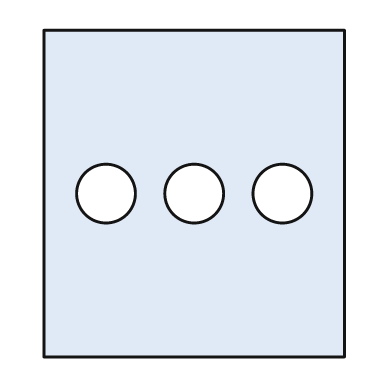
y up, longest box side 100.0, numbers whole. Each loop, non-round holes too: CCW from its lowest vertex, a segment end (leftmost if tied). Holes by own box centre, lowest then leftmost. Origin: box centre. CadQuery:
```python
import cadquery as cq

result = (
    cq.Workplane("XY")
    .moveTo(-46.0, -50.0)
    .lineTo(46.0, -50.0)
    .lineTo(46.0, 50.0)
    .lineTo(-46.0, 50.0)
    .close()
    .moveTo(-27.0, 0.0)
    .circle(9.0)
    .moveTo(0.0, 0.0)
    .circle(9.0)
    .moveTo(27.0, 0.0)
    .circle(9.0)
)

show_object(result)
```